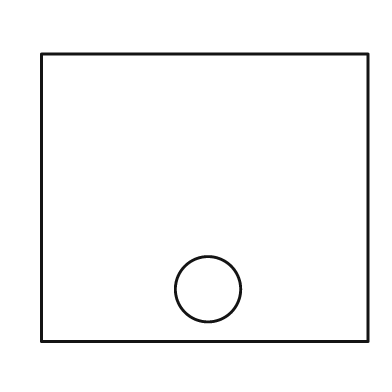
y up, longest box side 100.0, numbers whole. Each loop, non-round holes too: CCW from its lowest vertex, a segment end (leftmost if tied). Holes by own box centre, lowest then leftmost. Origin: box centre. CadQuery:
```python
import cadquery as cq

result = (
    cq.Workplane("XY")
    .moveTo(-50.0, -44.0)
    .lineTo(50.0, -44.0)
    .lineTo(50.0, 44.0)
    .lineTo(-50.0, 44.0)
    .close()
    .moveTo(1.0, -28.0)
    .circle(10.0)
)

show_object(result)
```